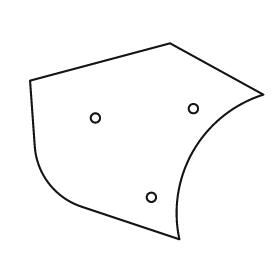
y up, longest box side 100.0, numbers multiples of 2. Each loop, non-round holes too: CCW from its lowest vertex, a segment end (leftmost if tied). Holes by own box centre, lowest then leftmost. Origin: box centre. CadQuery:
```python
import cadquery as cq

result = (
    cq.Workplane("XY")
    .moveTo(14.0, -42.0)
    .threePointArc((20.0, -4.0), (50.0, 20.0))
    .lineTo(10.0, 42.0)
    .lineTo(-50.0, 26.0)
    .lineTo(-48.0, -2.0)
    .threePointArc((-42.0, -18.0), (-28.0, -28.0))
    .close()
    .moveTo(2.0, -24.0)
    .circle(2.0)
    .moveTo(-22.0, 10.0)
    .circle(2.0)
    .moveTo(20.0, 14.0)
    .circle(2.0)
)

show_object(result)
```